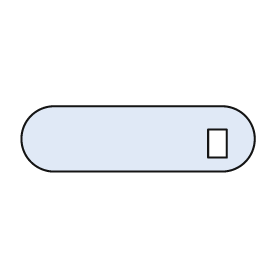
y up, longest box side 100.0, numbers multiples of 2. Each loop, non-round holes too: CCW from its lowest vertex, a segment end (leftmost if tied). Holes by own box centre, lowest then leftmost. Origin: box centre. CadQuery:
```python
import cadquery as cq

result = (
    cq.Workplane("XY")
    .moveTo(-36.0, -14.0)
    .lineTo(36.0, -14.0)
    .threePointArc((50.0, 0.0), (36.0, 14.0))
    .lineTo(-36.0, 14.0)
    .threePointArc((-50.0, 0.0), (-36.0, -14.0))
    .close()
    .moveTo(30.0, -8.0)
    .lineTo(38.0, -8.0)
    .lineTo(38.0, 4.0)
    .lineTo(30.0, 4.0)
    .close()
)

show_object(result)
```